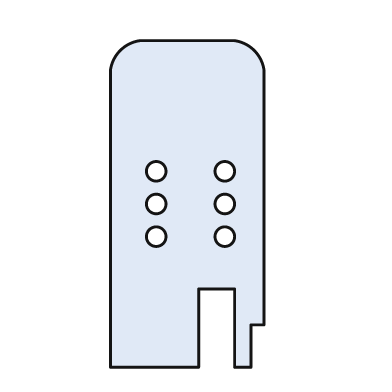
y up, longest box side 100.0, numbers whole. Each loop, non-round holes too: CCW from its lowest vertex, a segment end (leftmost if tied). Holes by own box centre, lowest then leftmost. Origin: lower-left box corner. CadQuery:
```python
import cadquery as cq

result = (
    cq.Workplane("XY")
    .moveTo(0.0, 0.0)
    .lineTo(27.0, 0.0)
    .lineTo(27.0, 24.0)
    .lineTo(38.0, 24.0)
    .lineTo(38.0, 0.0)
    .lineTo(43.0, 0.0)
    .lineTo(43.0, 13.0)
    .lineTo(47.0, 13.0)
    .lineTo(47.0, 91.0)
    .threePointArc((44.0, 97.0), (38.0, 100.0))
    .lineTo(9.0, 100.0)
    .threePointArc((3.0, 97.0), (0.0, 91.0))
    .close()
    .moveTo(14.0, 40.0)
    .circle(3.0)
    .moveTo(35.0, 40.0)
    .circle(3.0)
    .moveTo(14.0, 50.0)
    .circle(3.0)
    .moveTo(35.0, 50.0)
    .circle(3.0)
    .moveTo(14.0, 60.0)
    .circle(3.0)
    .moveTo(35.0, 60.0)
    .circle(3.0)
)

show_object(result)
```